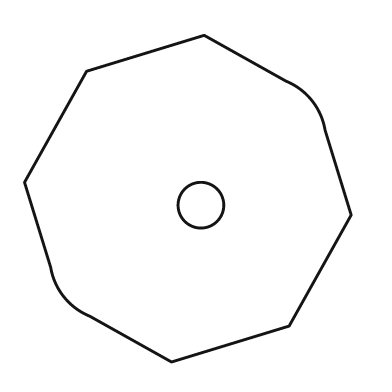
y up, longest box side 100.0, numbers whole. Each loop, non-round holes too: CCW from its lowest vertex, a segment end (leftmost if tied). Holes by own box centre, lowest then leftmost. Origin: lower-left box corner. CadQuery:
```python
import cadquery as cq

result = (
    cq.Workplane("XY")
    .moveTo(45.0, 0.0)
    .lineTo(81.0, 11.0)
    .lineTo(100.0, 45.0)
    .lineTo(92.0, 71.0)
    .threePointArc((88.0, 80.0), (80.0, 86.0))
    .lineTo(55.0, 100.0)
    .lineTo(19.0, 89.0)
    .lineTo(0.0, 55.0)
    .lineTo(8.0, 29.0)
    .threePointArc((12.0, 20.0), (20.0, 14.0))
    .close()
    .moveTo(54.0, 48.0)
    .circle(7.0)
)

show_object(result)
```